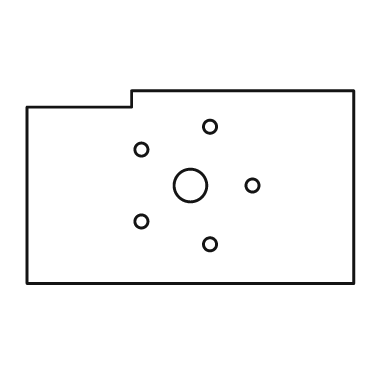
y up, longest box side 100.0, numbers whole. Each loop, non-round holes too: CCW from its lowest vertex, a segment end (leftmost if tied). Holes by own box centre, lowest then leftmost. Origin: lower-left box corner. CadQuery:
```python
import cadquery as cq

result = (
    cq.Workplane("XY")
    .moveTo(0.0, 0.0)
    .lineTo(100.0, 0.0)
    .lineTo(100.0, 59.0)
    .lineTo(32.0, 59.0)
    .lineTo(32.0, 54.0)
    .lineTo(0.0, 54.0)
    .close()
    .moveTo(56.0, 12.0)
    .circle(2.0)
    .moveTo(35.0, 19.0)
    .circle(2.0)
    .moveTo(50.0, 30.0)
    .circle(5.0)
    .moveTo(69.0, 30.0)
    .circle(2.0)
    .moveTo(35.0, 41.0)
    .circle(2.0)
    .moveTo(56.0, 48.0)
    .circle(2.0)
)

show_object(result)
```